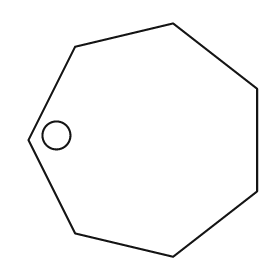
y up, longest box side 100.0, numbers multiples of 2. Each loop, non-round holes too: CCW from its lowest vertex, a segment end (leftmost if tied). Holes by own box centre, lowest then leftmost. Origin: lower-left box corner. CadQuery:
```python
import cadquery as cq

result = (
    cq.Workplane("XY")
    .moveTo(62.0, 0.0)
    .lineTo(98.0, 28.0)
    .lineTo(98.0, 72.0)
    .lineTo(62.0, 100.0)
    .lineTo(20.0, 90.0)
    .lineTo(0.0, 50.0)
    .lineTo(20.0, 10.0)
    .close()
    .moveTo(12.0, 52.0)
    .circle(6.0)
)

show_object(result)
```